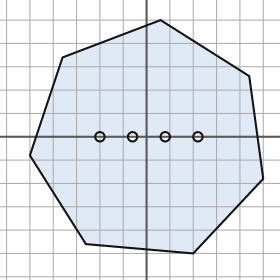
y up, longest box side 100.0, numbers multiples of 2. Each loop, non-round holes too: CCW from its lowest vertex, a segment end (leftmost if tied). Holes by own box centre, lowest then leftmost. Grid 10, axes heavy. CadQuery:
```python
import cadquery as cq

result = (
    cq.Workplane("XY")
    .moveTo(20.0, -50.0)
    .lineTo(50.0, -18.0)
    .lineTo(44.0, 26.0)
    .lineTo(6.0, 50.0)
    .lineTo(-36.0, 34.0)
    .lineTo(-50.0, -8.0)
    .lineTo(-26.0, -46.0)
    .close()
    .moveTo(-20.0, 0.0)
    .circle(2.0)
    .moveTo(-6.0, 0.0)
    .circle(2.0)
    .moveTo(8.0, 0.0)
    .circle(2.0)
    .moveTo(22.0, 0.0)
    .circle(2.0)
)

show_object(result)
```